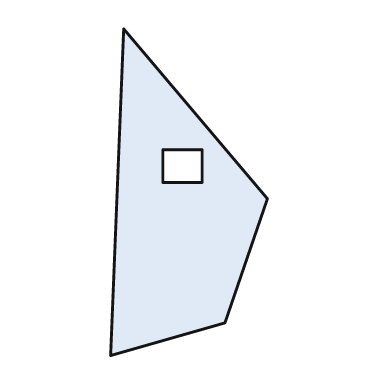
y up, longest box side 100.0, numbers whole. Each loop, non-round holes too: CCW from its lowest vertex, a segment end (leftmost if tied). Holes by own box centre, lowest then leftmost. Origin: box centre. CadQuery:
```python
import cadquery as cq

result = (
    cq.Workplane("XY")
    .moveTo(-24.0, -50.0)
    .lineTo(11.0, -40.0)
    .lineTo(24.0, -2.0)
    .lineTo(-20.0, 50.0)
    .close()
    .moveTo(-8.0, 3.0)
    .lineTo(4.0, 3.0)
    .lineTo(4.0, 13.0)
    .lineTo(-8.0, 13.0)
    .close()
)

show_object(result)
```